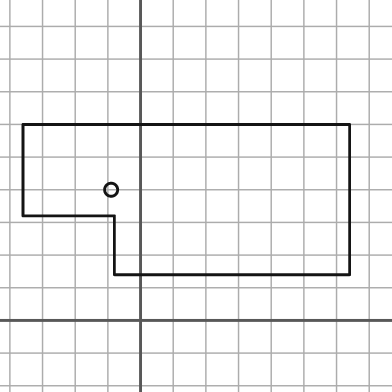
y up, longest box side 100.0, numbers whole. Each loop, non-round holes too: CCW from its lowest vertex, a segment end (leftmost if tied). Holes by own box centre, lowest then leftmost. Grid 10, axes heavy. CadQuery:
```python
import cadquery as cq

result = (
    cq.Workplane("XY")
    .moveTo(-8.0, 14.0)
    .lineTo(64.0, 14.0)
    .lineTo(64.0, 60.0)
    .lineTo(-36.0, 60.0)
    .lineTo(-36.0, 32.0)
    .lineTo(-8.0, 32.0)
    .close()
    .moveTo(-9.0, 40.0)
    .circle(2.0)
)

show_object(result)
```